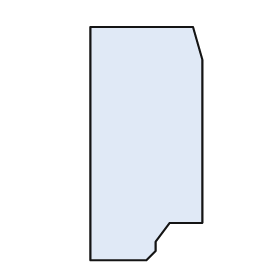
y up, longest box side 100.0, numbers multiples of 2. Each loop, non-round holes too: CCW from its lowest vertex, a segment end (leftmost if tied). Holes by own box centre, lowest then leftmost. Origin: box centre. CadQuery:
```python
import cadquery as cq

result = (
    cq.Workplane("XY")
    .moveTo(-24.0, -50.0)
    .lineTo(0.0, -50.0)
    .lineTo(4.0, -46.0)
    .lineTo(4.0, -42.0)
    .lineTo(10.0, -34.0)
    .lineTo(24.0, -34.0)
    .lineTo(24.0, 36.0)
    .lineTo(20.0, 50.0)
    .lineTo(-24.0, 50.0)
    .close()
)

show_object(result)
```